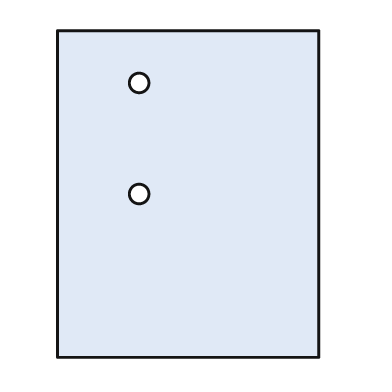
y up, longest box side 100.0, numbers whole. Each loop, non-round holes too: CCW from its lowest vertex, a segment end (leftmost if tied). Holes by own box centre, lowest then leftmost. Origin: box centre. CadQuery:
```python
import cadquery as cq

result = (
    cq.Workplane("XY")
    .moveTo(-40.0, -50.0)
    .lineTo(40.0, -50.0)
    .lineTo(40.0, 50.0)
    .lineTo(-40.0, 50.0)
    .close()
    .moveTo(-15.0, 0.0)
    .circle(3.0)
    .moveTo(-15.0, 34.0)
    .circle(3.0)
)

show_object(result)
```